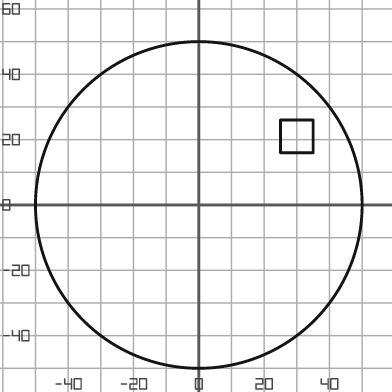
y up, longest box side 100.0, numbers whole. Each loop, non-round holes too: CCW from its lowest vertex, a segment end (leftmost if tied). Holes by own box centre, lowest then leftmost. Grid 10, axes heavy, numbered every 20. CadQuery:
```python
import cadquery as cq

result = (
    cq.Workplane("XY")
    .moveTo(0.0, 0.0)
    .circle(50.0)
    .moveTo(25.0, 16.0)
    .lineTo(35.0, 16.0)
    .lineTo(35.0, 26.0)
    .lineTo(25.0, 26.0)
    .close()
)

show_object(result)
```